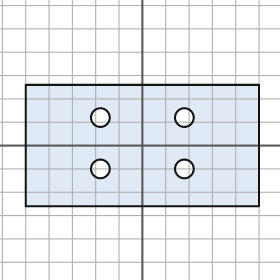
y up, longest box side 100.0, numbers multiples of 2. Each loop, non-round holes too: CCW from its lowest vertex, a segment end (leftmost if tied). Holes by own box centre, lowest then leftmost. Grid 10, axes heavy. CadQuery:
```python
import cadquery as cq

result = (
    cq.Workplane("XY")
    .moveTo(-50.0, -26.0)
    .lineTo(50.0, -26.0)
    .lineTo(50.0, 26.0)
    .lineTo(-50.0, 26.0)
    .close()
    .moveTo(-18.0, -10.0)
    .circle(4.0)
    .moveTo(18.0, -10.0)
    .circle(4.0)
    .moveTo(-18.0, 12.0)
    .circle(4.0)
    .moveTo(18.0, 12.0)
    .circle(4.0)
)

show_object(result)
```